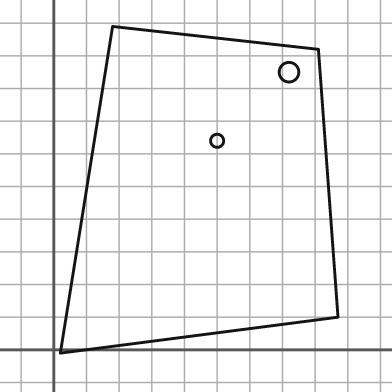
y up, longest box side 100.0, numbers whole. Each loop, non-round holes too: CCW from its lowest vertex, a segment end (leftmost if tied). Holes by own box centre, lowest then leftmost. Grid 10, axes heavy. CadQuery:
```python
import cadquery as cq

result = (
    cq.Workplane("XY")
    .moveTo(2.0, -1.0)
    .lineTo(87.0, 10.0)
    .lineTo(81.0, 92.0)
    .lineTo(18.0, 99.0)
    .close()
    .moveTo(50.0, 64.0)
    .circle(2.0)
    .moveTo(72.0, 85.0)
    .circle(3.0)
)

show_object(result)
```